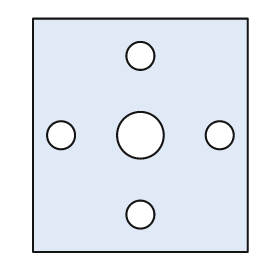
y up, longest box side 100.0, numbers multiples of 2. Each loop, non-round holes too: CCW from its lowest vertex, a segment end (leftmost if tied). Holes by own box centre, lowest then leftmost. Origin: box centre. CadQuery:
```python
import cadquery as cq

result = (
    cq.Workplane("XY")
    .moveTo(-46.0, -50.0)
    .lineTo(46.0, -50.0)
    .lineTo(46.0, 50.0)
    .lineTo(-46.0, 50.0)
    .close()
    .moveTo(0.0, -34.0)
    .circle(6.0)
    .moveTo(-34.0, 0.0)
    .circle(6.0)
    .moveTo(0.0, 0.0)
    .circle(10.0)
    .moveTo(34.0, 0.0)
    .circle(6.0)
    .moveTo(0.0, 34.0)
    .circle(6.0)
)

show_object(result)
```